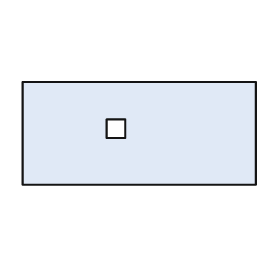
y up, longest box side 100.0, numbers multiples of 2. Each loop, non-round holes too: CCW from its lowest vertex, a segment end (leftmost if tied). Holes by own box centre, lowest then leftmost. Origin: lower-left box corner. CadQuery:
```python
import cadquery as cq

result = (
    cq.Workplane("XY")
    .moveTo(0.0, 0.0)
    .lineTo(100.0, 0.0)
    .lineTo(100.0, 44.0)
    .lineTo(0.0, 44.0)
    .close()
    .moveTo(36.0, 20.0)
    .lineTo(44.0, 20.0)
    .lineTo(44.0, 28.0)
    .lineTo(36.0, 28.0)
    .close()
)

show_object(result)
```